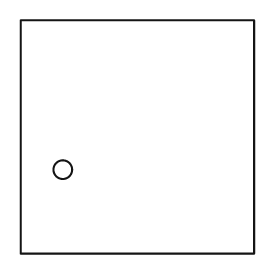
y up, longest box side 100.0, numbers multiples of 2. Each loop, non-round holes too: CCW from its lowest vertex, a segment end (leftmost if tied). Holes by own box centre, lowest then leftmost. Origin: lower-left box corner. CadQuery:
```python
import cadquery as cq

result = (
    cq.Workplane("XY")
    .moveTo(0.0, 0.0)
    .lineTo(100.0, 0.0)
    .lineTo(100.0, 100.0)
    .lineTo(0.0, 100.0)
    .close()
    .moveTo(18.0, 36.0)
    .circle(4.0)
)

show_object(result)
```